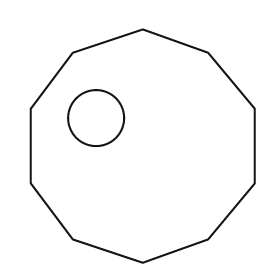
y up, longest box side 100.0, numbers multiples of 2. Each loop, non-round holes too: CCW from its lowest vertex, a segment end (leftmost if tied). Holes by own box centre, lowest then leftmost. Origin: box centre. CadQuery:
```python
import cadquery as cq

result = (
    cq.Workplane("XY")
    .moveTo(0.0, -50.0)
    .lineTo(28.0, -40.0)
    .lineTo(48.0, -16.0)
    .lineTo(48.0, 16.0)
    .lineTo(28.0, 40.0)
    .lineTo(0.0, 50.0)
    .lineTo(-30.0, 40.0)
    .lineTo(-48.0, 16.0)
    .lineTo(-48.0, -16.0)
    .lineTo(-30.0, -40.0)
    .close()
    .moveTo(-20.0, 12.0)
    .circle(12.0)
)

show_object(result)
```